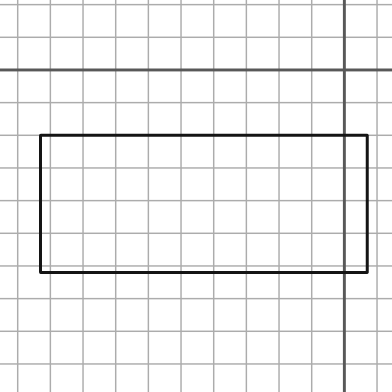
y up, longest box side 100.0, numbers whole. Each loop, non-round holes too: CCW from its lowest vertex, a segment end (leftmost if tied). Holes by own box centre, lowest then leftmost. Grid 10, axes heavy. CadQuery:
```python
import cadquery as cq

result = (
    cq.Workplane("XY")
    .moveTo(-93.0, -62.0)
    .lineTo(7.0, -62.0)
    .lineTo(7.0, -20.0)
    .lineTo(-93.0, -20.0)
    .close()
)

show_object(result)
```